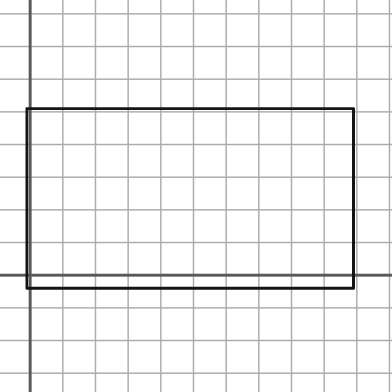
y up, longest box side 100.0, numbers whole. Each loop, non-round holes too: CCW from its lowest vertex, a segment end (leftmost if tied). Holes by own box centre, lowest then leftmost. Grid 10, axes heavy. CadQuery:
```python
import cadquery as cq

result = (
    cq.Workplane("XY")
    .moveTo(-1.0, -4.0)
    .lineTo(99.0, -4.0)
    .lineTo(99.0, 51.0)
    .lineTo(-1.0, 51.0)
    .close()
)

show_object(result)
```